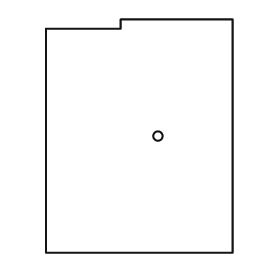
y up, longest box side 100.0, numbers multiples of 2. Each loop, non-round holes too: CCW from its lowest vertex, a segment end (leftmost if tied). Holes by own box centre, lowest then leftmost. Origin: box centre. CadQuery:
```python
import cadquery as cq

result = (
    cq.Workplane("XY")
    .moveTo(-40.0, -50.0)
    .lineTo(40.0, -50.0)
    .lineTo(40.0, 50.0)
    .lineTo(-8.0, 50.0)
    .lineTo(-8.0, 46.0)
    .lineTo(-40.0, 46.0)
    .close()
    .moveTo(8.0, 0.0)
    .circle(2.0)
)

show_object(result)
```